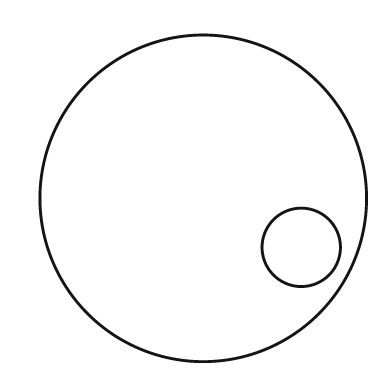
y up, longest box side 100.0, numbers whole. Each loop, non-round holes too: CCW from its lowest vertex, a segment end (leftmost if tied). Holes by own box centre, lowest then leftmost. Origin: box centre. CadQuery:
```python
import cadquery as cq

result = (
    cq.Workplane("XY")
    .moveTo(0.0, 0.0)
    .circle(50.0)
    .moveTo(30.0, -15.0)
    .circle(12.0)
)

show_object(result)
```